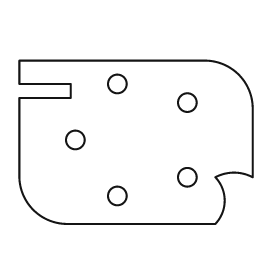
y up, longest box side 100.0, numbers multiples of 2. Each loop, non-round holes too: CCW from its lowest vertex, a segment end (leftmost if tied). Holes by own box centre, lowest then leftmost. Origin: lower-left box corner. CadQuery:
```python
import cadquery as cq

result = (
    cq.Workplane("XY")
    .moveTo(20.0, 0.0)
    .lineTo(84.0, 0.0)
    .threePointArc((88.0, 10.0), (84.0, 20.0))
    .threePointArc((92.0, 22.0), (100.0, 20.0))
    .lineTo(100.0, 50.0)
    .threePointArc((94.0, 64.0), (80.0, 70.0))
    .lineTo(0.0, 70.0)
    .lineTo(0.0, 60.0)
    .lineTo(22.0, 60.0)
    .lineTo(22.0, 54.0)
    .lineTo(0.0, 54.0)
    .lineTo(0.0, 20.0)
    .threePointArc((6.0, 6.0), (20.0, 0.0))
    .close()
    .moveTo(42.0, 12.0)
    .circle(4.0)
    .moveTo(72.0, 20.0)
    .circle(4.0)
    .moveTo(24.0, 36.0)
    .circle(4.0)
    .moveTo(72.0, 52.0)
    .circle(4.0)
    .moveTo(42.0, 60.0)
    .circle(4.0)
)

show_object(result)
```